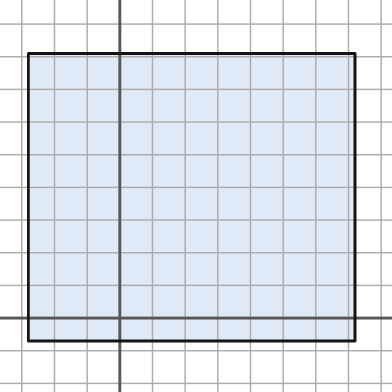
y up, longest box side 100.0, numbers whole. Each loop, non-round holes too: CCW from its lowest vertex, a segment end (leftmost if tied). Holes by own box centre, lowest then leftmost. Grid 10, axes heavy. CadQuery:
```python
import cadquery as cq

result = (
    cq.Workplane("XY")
    .moveTo(-28.0, -7.0)
    .lineTo(72.0, -7.0)
    .lineTo(72.0, 81.0)
    .lineTo(-28.0, 81.0)
    .close()
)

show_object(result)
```